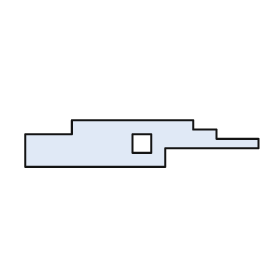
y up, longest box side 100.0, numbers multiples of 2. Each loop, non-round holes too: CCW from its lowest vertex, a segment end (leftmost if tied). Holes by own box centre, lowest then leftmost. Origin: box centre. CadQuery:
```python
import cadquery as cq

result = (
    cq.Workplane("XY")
    .moveTo(-50.0, -10.0)
    .lineTo(10.0, -10.0)
    .lineTo(10.0, -2.0)
    .lineTo(50.0, -2.0)
    .lineTo(50.0, 2.0)
    .lineTo(32.0, 2.0)
    .lineTo(32.0, 6.0)
    .lineTo(22.0, 6.0)
    .lineTo(22.0, 10.0)
    .lineTo(-30.0, 10.0)
    .lineTo(-30.0, 4.0)
    .lineTo(-50.0, 4.0)
    .close()
    .moveTo(-4.0, -4.0)
    .lineTo(4.0, -4.0)
    .lineTo(4.0, 4.0)
    .lineTo(-4.0, 4.0)
    .close()
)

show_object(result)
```